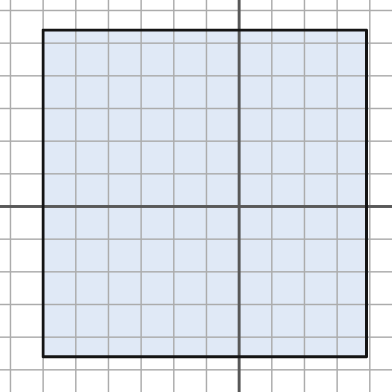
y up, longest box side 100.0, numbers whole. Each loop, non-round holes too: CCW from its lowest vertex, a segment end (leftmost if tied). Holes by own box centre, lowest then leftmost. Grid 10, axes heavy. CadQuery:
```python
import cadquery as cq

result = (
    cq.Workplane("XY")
    .moveTo(-60.0, -46.0)
    .lineTo(39.0, -46.0)
    .lineTo(39.0, 54.0)
    .lineTo(-60.0, 54.0)
    .close()
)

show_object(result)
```